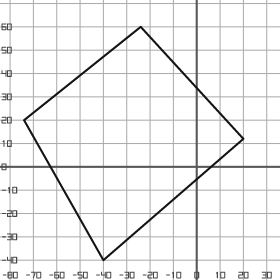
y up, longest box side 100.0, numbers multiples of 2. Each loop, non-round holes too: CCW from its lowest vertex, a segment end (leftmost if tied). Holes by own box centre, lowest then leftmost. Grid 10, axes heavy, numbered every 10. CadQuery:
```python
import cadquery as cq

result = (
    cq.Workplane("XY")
    .moveTo(-40.0, -40.0)
    .lineTo(20.0, 12.0)
    .lineTo(-24.0, 60.0)
    .lineTo(-74.0, 20.0)
    .close()
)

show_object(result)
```